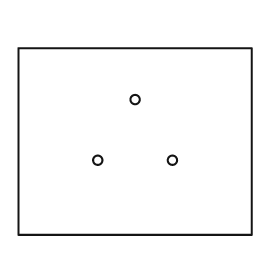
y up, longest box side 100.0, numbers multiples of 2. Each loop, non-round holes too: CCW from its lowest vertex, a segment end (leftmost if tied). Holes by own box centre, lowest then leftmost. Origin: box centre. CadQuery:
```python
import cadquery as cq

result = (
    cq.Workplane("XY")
    .moveTo(-50.0, -40.0)
    .lineTo(50.0, -40.0)
    .lineTo(50.0, 40.0)
    .lineTo(-50.0, 40.0)
    .close()
    .moveTo(-16.0, -8.0)
    .circle(2.0)
    .moveTo(16.0, -8.0)
    .circle(2.0)
    .moveTo(0.0, 18.0)
    .circle(2.0)
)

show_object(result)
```